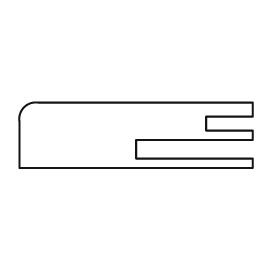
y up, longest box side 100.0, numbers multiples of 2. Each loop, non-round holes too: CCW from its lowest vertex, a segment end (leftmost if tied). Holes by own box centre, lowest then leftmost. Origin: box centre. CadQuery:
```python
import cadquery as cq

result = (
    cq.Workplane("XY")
    .moveTo(-50.0, -14.0)
    .lineTo(50.0, -14.0)
    .lineTo(50.0, -10.0)
    .lineTo(0.0, -10.0)
    .lineTo(0.0, -2.0)
    .lineTo(50.0, -2.0)
    .lineTo(50.0, 2.0)
    .lineTo(30.0, 2.0)
    .lineTo(30.0, 8.0)
    .lineTo(50.0, 8.0)
    .lineTo(50.0, 14.0)
    .lineTo(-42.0, 14.0)
    .threePointArc((-48.0, 12.0), (-50.0, 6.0))
    .close()
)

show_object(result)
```